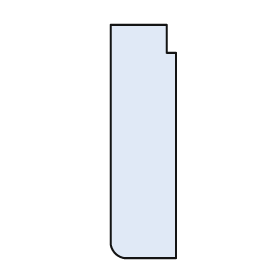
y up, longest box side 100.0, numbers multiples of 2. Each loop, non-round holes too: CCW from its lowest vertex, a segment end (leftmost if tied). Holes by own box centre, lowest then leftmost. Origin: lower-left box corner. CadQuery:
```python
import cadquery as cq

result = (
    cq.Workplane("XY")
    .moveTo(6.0, 0.0)
    .lineTo(28.0, 0.0)
    .lineTo(28.0, 88.0)
    .lineTo(24.0, 88.0)
    .lineTo(24.0, 100.0)
    .lineTo(0.0, 100.0)
    .lineTo(0.0, 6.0)
    .threePointArc((2.0, 2.0), (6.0, 0.0))
    .close()
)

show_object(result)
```